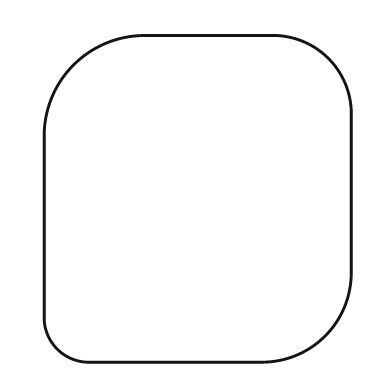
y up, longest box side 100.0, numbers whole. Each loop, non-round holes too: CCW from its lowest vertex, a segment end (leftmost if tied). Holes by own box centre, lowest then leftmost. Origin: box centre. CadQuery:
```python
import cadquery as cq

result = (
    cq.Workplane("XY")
    .moveTo(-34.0, -50.0)
    .lineTo(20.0, -50.0)
    .threePointArc((39.0, -42.0), (47.0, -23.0))
    .lineTo(47.0, 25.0)
    .threePointArc((40.0, 43.0), (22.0, 50.0))
    .lineTo(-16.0, 50.0)
    .threePointArc((-38.0, 41.0), (-47.0, 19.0))
    .lineTo(-47.0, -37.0)
    .threePointArc((-43.0, -46.0), (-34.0, -50.0))
    .close()
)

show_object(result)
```